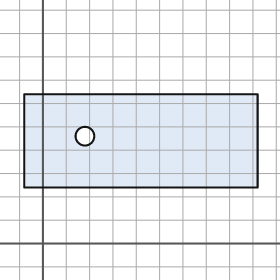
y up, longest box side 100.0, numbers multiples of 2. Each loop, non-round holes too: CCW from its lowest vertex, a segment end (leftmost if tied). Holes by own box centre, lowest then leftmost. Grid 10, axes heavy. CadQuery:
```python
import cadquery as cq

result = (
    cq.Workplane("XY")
    .moveTo(-8.0, 24.0)
    .lineTo(92.0, 24.0)
    .lineTo(92.0, 64.0)
    .lineTo(-8.0, 64.0)
    .close()
    .moveTo(18.0, 46.0)
    .circle(4.0)
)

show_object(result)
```